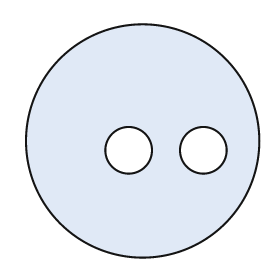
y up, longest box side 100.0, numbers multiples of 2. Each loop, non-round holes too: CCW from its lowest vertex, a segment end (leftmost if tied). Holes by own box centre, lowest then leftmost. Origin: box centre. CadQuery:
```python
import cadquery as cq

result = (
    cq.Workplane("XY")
    .moveTo(0.0, 0.0)
    .circle(50.0)
    .moveTo(-6.0, -4.0)
    .circle(10.0)
    .moveTo(26.0, -4.0)
    .circle(10.0)
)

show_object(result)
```